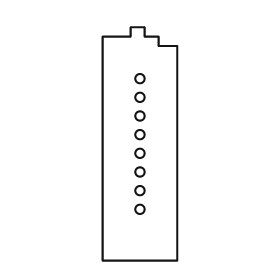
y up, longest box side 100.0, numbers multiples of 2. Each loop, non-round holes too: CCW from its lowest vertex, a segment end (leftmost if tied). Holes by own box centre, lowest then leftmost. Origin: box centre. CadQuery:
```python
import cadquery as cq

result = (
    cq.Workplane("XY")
    .moveTo(-16.0, -50.0)
    .lineTo(16.0, -50.0)
    .lineTo(16.0, 42.0)
    .lineTo(8.0, 42.0)
    .lineTo(8.0, 46.0)
    .lineTo(2.0, 46.0)
    .lineTo(2.0, 50.0)
    .lineTo(-4.0, 50.0)
    .lineTo(-4.0, 46.0)
    .lineTo(-16.0, 46.0)
    .close()
    .moveTo(0.0, -28.0)
    .circle(2.0)
    .moveTo(0.0, -20.0)
    .circle(2.0)
    .moveTo(0.0, -12.0)
    .circle(2.0)
    .moveTo(0.0, -4.0)
    .circle(2.0)
    .moveTo(0.0, 4.0)
    .circle(2.0)
    .moveTo(0.0, 12.0)
    .circle(2.0)
    .moveTo(0.0, 20.0)
    .circle(2.0)
    .moveTo(0.0, 28.0)
    .circle(2.0)
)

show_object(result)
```